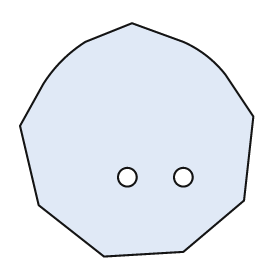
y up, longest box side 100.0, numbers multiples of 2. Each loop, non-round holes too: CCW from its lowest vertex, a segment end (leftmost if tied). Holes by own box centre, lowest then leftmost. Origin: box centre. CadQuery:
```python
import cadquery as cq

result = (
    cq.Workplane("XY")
    .moveTo(-14.0, -50.0)
    .lineTo(20.0, -48.0)
    .lineTo(46.0, -26.0)
    .lineTo(50.0, 10.0)
    .lineTo(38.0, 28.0)
    .threePointArc((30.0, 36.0), (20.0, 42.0))
    .lineTo(-2.0, 50.0)
    .lineTo(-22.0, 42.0)
    .threePointArc((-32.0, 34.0), (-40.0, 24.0))
    .lineTo(-50.0, 6.0)
    .lineTo(-42.0, -28.0)
    .close()
    .moveTo(-4.0, -16.0)
    .circle(4.0)
    .moveTo(20.0, -16.0)
    .circle(4.0)
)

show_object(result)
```